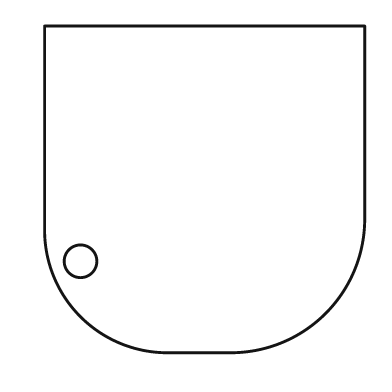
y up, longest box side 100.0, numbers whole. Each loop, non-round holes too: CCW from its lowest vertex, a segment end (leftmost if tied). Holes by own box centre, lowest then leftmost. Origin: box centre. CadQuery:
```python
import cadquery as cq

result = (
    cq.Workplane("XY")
    .moveTo(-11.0, -50.0)
    .lineTo(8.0, -50.0)
    .threePointArc((37.0, -38.0), (49.0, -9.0))
    .lineTo(49.0, 50.0)
    .lineTo(-49.0, 50.0)
    .lineTo(-49.0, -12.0)
    .threePointArc((-38.0, -39.0), (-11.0, -50.0))
    .close()
    .moveTo(-38.0, -22.0)
    .circle(5.0)
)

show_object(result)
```